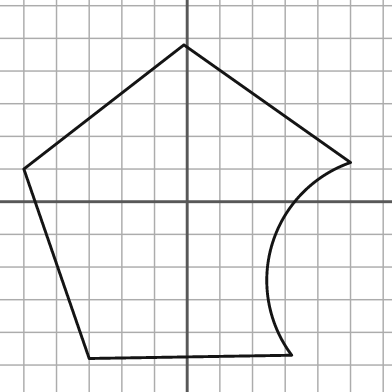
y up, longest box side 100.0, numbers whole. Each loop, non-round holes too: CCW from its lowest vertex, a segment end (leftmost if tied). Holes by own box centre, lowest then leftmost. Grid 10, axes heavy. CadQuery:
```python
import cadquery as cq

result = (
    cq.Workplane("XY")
    .moveTo(-30.0, -48.0)
    .lineTo(32.0, -47.0)
    .threePointArc((26.0, -13.0), (50.0, 12.0))
    .lineTo(-1.0, 48.0)
    .lineTo(-50.0, 10.0)
    .close()
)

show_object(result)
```